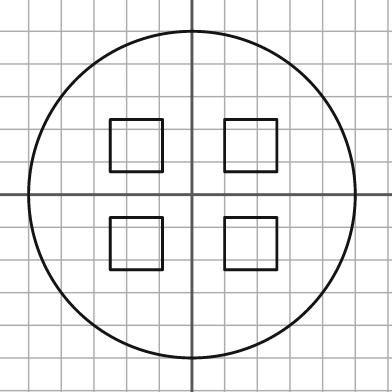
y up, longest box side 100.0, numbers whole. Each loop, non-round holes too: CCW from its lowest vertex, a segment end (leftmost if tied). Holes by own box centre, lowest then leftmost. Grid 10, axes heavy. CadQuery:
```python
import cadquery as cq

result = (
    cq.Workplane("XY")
    .moveTo(0.0, 0.0)
    .circle(50.0)
    .moveTo(-25.0, -23.0)
    .lineTo(-9.0, -23.0)
    .lineTo(-9.0, -7.0)
    .lineTo(-25.0, -7.0)
    .close()
    .moveTo(10.0, -23.0)
    .lineTo(26.0, -23.0)
    .lineTo(26.0, -7.0)
    .lineTo(10.0, -7.0)
    .close()
    .moveTo(-25.0, 7.0)
    .lineTo(-9.0, 7.0)
    .lineTo(-9.0, 23.0)
    .lineTo(-25.0, 23.0)
    .close()
    .moveTo(10.0, 7.0)
    .lineTo(26.0, 7.0)
    .lineTo(26.0, 23.0)
    .lineTo(10.0, 23.0)
    .close()
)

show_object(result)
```